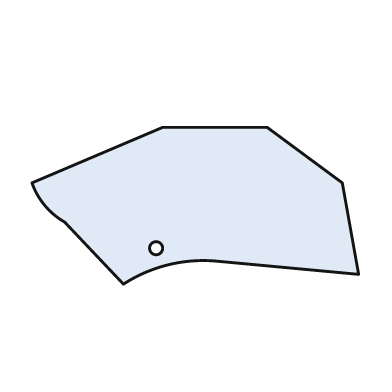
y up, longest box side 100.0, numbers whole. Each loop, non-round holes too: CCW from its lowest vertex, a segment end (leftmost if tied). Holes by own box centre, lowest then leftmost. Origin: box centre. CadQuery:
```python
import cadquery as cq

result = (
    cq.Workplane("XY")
    .moveTo(-22.0, -24.0)
    .threePointArc((-8.0, -18.0), (7.0, -17.0))
    .lineTo(50.0, -21.0)
    .lineTo(45.0, 7.0)
    .lineTo(22.0, 24.0)
    .lineTo(-10.0, 24.0)
    .lineTo(-50.0, 7.0)
    .threePointArc((-46.0, 0.0), (-40.0, -5.0))
    .close()
    .moveTo(-12.0, -13.0)
    .circle(2.0)
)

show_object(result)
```